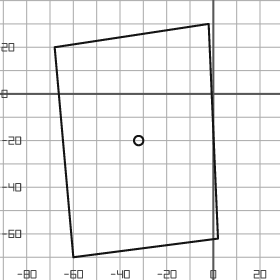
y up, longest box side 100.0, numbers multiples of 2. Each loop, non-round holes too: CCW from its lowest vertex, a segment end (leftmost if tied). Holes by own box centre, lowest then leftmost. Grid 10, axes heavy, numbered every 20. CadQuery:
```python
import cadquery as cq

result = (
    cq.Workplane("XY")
    .moveTo(-60.0, -70.0)
    .lineTo(2.0, -62.0)
    .lineTo(-2.0, 30.0)
    .lineTo(-68.0, 20.0)
    .close()
    .moveTo(-32.0, -20.0)
    .circle(2.0)
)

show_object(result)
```